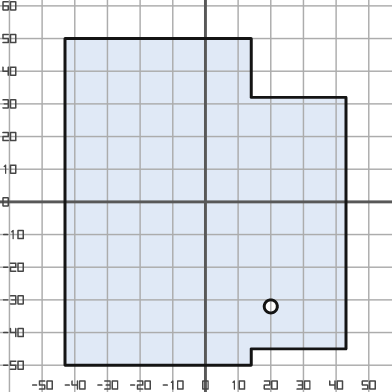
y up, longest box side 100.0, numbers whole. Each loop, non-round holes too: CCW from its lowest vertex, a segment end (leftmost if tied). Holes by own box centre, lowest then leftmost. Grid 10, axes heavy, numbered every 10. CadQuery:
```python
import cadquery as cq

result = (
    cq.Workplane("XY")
    .moveTo(-43.0, -50.0)
    .lineTo(14.0, -50.0)
    .lineTo(14.0, -45.0)
    .lineTo(43.0, -45.0)
    .lineTo(43.0, 32.0)
    .lineTo(14.0, 32.0)
    .lineTo(14.0, 50.0)
    .lineTo(-43.0, 50.0)
    .close()
    .moveTo(20.0, -32.0)
    .circle(2.0)
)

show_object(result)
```